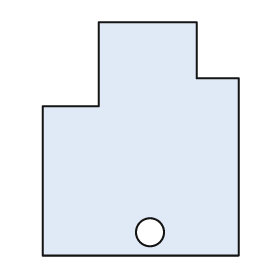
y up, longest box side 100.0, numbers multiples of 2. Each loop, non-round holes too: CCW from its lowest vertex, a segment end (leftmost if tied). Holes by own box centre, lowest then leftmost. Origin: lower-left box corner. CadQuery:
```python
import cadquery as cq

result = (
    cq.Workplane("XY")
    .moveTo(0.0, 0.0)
    .lineTo(84.0, 0.0)
    .lineTo(84.0, 76.0)
    .lineTo(66.0, 76.0)
    .lineTo(66.0, 100.0)
    .lineTo(24.0, 100.0)
    .lineTo(24.0, 64.0)
    .lineTo(0.0, 64.0)
    .close()
    .moveTo(46.0, 10.0)
    .circle(6.0)
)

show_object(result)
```